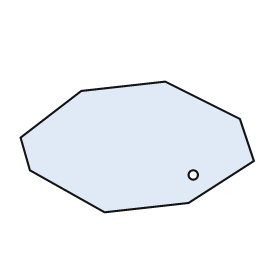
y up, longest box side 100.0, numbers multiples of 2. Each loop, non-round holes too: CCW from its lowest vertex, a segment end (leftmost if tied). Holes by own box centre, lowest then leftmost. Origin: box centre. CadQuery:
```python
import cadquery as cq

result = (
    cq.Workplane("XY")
    .moveTo(-14.0, -28.0)
    .lineTo(22.0, -24.0)
    .lineTo(50.0, -6.0)
    .lineTo(44.0, 12.0)
    .lineTo(12.0, 28.0)
    .lineTo(-24.0, 24.0)
    .lineTo(-50.0, 4.0)
    .lineTo(-46.0, -10.0)
    .close()
    .moveTo(24.0, -12.0)
    .circle(2.0)
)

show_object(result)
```